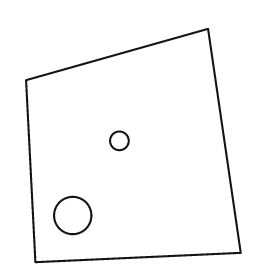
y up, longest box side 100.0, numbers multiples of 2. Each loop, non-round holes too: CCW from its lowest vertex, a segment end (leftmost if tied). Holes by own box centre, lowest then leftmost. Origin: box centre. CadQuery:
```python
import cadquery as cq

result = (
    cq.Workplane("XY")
    .moveTo(-42.0, -50.0)
    .lineTo(46.0, -46.0)
    .lineTo(32.0, 50.0)
    .lineTo(-46.0, 28.0)
    .close()
    .moveTo(-26.0, -30.0)
    .circle(8.0)
    .moveTo(-6.0, 2.0)
    .circle(4.0)
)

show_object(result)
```